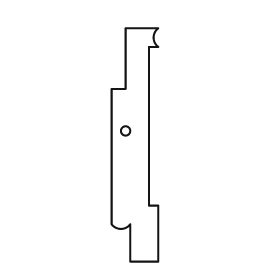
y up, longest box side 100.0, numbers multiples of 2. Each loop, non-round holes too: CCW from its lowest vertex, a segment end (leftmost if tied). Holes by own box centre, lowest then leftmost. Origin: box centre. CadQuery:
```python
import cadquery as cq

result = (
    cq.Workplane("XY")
    .moveTo(-2.0, -50.0)
    .lineTo(10.0, -50.0)
    .lineTo(10.0, -26.0)
    .lineTo(6.0, -26.0)
    .lineTo(6.0, 42.0)
    .lineTo(10.0, 42.0)
    .threePointArc((8.0, 46.0), (10.0, 50.0))
    .lineTo(-4.0, 50.0)
    .lineTo(-4.0, 24.0)
    .lineTo(-10.0, 24.0)
    .lineTo(-10.0, -34.0)
    .threePointArc((-6.0, -36.0), (-2.0, -34.0))
    .close()
    .moveTo(-4.0, 6.0)
    .circle(2.0)
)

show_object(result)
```